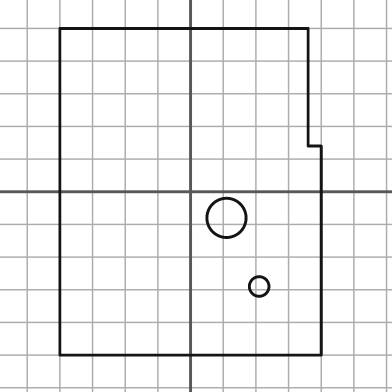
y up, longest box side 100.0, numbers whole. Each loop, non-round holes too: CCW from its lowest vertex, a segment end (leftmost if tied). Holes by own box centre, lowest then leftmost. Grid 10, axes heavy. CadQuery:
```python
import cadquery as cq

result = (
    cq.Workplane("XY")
    .moveTo(-40.0, -50.0)
    .lineTo(40.0, -50.0)
    .lineTo(40.0, 14.0)
    .lineTo(36.0, 14.0)
    .lineTo(36.0, 50.0)
    .lineTo(-40.0, 50.0)
    .close()
    .moveTo(21.0, -29.0)
    .circle(3.0)
    .moveTo(11.0, -8.0)
    .circle(6.0)
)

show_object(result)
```